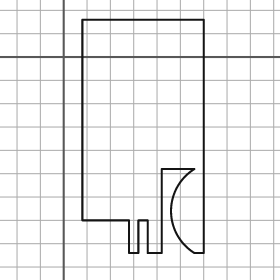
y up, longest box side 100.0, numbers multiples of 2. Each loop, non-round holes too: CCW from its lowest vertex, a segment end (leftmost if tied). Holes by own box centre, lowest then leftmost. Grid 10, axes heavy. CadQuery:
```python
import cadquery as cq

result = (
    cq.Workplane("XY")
    .moveTo(28.0, -84.0)
    .lineTo(32.0, -84.0)
    .lineTo(32.0, -70.0)
    .lineTo(36.0, -70.0)
    .lineTo(36.0, -84.0)
    .lineTo(42.0, -84.0)
    .lineTo(42.0, -48.0)
    .lineTo(56.0, -48.0)
    .threePointArc((46.0, -66.0), (56.0, -84.0))
    .lineTo(60.0, -84.0)
    .lineTo(60.0, 16.0)
    .lineTo(8.0, 16.0)
    .lineTo(8.0, -70.0)
    .lineTo(28.0, -70.0)
    .close()
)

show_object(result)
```